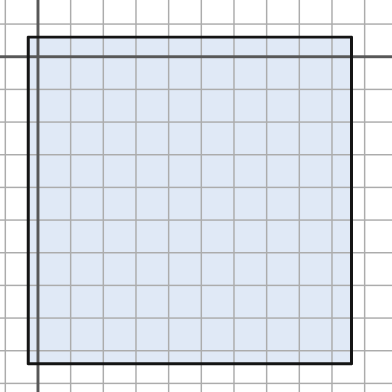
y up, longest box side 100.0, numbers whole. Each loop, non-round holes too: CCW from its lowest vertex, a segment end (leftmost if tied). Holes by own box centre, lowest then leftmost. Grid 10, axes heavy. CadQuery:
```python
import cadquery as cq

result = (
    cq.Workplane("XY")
    .moveTo(-3.0, -94.0)
    .lineTo(96.0, -94.0)
    .lineTo(96.0, 6.0)
    .lineTo(-3.0, 6.0)
    .close()
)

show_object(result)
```